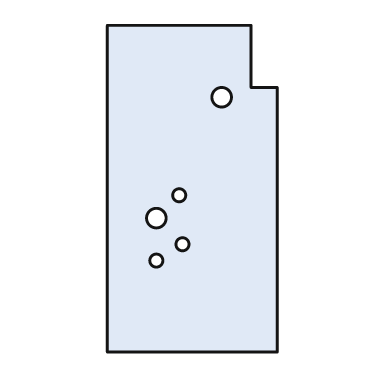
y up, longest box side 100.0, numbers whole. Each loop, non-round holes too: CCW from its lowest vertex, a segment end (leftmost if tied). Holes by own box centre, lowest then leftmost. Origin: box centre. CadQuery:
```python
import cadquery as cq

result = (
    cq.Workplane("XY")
    .moveTo(-26.0, -50.0)
    .lineTo(26.0, -50.0)
    .lineTo(26.0, 31.0)
    .lineTo(18.0, 31.0)
    .lineTo(18.0, 50.0)
    .lineTo(-26.0, 50.0)
    .close()
    .moveTo(-11.0, -22.0)
    .circle(2.0)
    .moveTo(-3.0, -17.0)
    .circle(2.0)
    .moveTo(-11.0, -9.0)
    .circle(3.0)
    .moveTo(-4.0, -2.0)
    .circle(2.0)
    .moveTo(9.0, 28.0)
    .circle(3.0)
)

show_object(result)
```